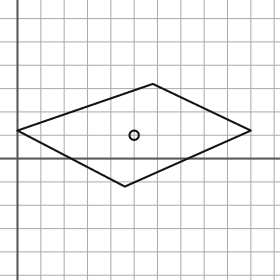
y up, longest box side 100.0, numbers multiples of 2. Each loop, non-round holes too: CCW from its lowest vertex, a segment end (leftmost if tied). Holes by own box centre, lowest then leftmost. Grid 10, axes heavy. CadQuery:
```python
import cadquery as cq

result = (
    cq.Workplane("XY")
    .moveTo(46.0, -12.0)
    .lineTo(100.0, 12.0)
    .lineTo(58.0, 32.0)
    .lineTo(0.0, 12.0)
    .close()
    .moveTo(50.0, 10.0)
    .circle(2.0)
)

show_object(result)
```